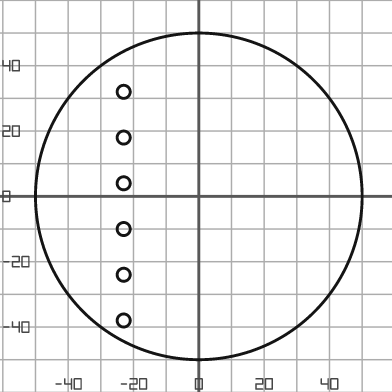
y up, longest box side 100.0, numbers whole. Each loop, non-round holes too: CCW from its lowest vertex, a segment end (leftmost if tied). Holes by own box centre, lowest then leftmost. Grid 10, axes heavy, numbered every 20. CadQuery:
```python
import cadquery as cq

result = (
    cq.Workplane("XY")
    .moveTo(0.0, 0.0)
    .circle(50.0)
    .moveTo(-23.0, -38.0)
    .circle(2.0)
    .moveTo(-23.0, -24.0)
    .circle(2.0)
    .moveTo(-23.0, -10.0)
    .circle(2.0)
    .moveTo(-23.0, 4.0)
    .circle(2.0)
    .moveTo(-23.0, 18.0)
    .circle(2.0)
    .moveTo(-23.0, 32.0)
    .circle(2.0)
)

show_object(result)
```